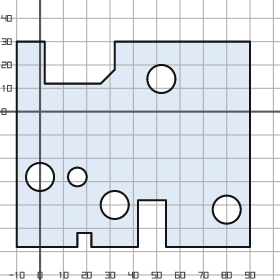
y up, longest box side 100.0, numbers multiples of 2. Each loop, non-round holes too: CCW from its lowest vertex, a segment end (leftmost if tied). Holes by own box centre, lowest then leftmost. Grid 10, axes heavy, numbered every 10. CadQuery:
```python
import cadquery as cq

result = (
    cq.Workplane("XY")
    .moveTo(-10.0, -58.0)
    .lineTo(16.0, -58.0)
    .lineTo(16.0, -52.0)
    .lineTo(22.0, -52.0)
    .lineTo(22.0, -58.0)
    .lineTo(42.0, -58.0)
    .lineTo(42.0, -38.0)
    .lineTo(54.0, -38.0)
    .lineTo(54.0, -58.0)
    .lineTo(90.0, -58.0)
    .lineTo(90.0, 30.0)
    .lineTo(32.0, 30.0)
    .lineTo(32.0, 18.0)
    .lineTo(26.0, 12.0)
    .lineTo(2.0, 12.0)
    .lineTo(2.0, 30.0)
    .lineTo(-10.0, 30.0)
    .close()
    .moveTo(80.0, -42.0)
    .circle(6.0)
    .moveTo(32.0, -40.0)
    .circle(6.0)
    .moveTo(0.0, -28.0)
    .circle(6.0)
    .moveTo(16.0, -28.0)
    .circle(4.0)
    .moveTo(52.0, 14.0)
    .circle(6.0)
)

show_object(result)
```